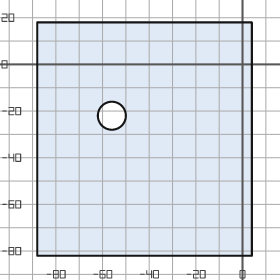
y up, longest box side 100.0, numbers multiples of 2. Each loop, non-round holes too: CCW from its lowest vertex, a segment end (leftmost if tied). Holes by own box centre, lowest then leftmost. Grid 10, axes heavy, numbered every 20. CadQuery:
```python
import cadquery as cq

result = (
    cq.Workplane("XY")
    .moveTo(-88.0, -82.0)
    .lineTo(4.0, -82.0)
    .lineTo(4.0, 18.0)
    .lineTo(-88.0, 18.0)
    .close()
    .moveTo(-56.0, -22.0)
    .circle(6.0)
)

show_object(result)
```